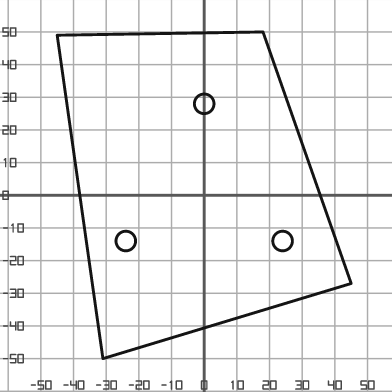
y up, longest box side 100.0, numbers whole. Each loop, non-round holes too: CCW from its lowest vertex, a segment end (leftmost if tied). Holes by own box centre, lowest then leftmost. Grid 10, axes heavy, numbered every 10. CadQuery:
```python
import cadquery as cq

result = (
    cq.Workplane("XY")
    .moveTo(-31.0, -50.0)
    .lineTo(45.0, -27.0)
    .lineTo(18.0, 50.0)
    .lineTo(-45.0, 49.0)
    .close()
    .moveTo(-24.0, -14.0)
    .circle(3.0)
    .moveTo(24.0, -14.0)
    .circle(3.0)
    .moveTo(0.0, 28.0)
    .circle(3.0)
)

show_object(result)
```